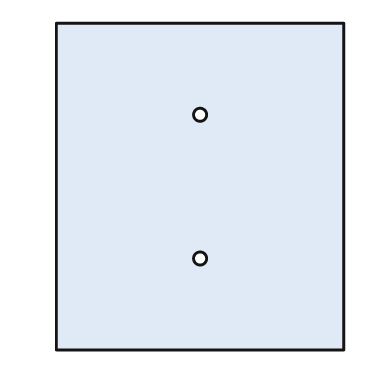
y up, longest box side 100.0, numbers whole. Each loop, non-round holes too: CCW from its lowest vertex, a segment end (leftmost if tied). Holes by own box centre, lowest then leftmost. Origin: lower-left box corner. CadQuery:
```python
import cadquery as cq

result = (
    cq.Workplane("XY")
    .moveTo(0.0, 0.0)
    .lineTo(88.0, 0.0)
    .lineTo(88.0, 100.0)
    .lineTo(0.0, 100.0)
    .close()
    .moveTo(44.0, 28.0)
    .circle(2.0)
    .moveTo(44.0, 72.0)
    .circle(2.0)
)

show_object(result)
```